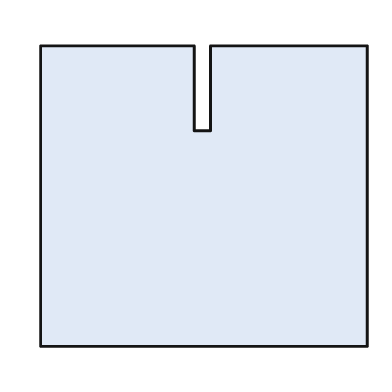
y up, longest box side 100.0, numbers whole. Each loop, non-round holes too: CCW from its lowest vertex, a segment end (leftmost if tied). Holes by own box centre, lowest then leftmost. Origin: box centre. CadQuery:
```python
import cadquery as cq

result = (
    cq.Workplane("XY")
    .moveTo(-50.0, -46.0)
    .lineTo(50.0, -46.0)
    .lineTo(50.0, 46.0)
    .lineTo(2.0, 46.0)
    .lineTo(2.0, 20.0)
    .lineTo(-3.0, 20.0)
    .lineTo(-3.0, 46.0)
    .lineTo(-50.0, 46.0)
    .close()
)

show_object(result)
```